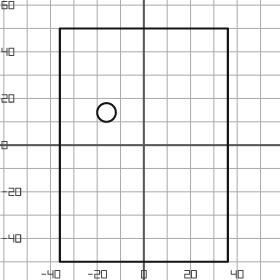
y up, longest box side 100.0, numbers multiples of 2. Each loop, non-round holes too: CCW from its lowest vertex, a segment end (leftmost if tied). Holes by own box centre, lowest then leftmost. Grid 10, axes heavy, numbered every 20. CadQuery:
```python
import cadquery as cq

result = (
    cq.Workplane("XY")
    .moveTo(-36.0, -50.0)
    .lineTo(36.0, -50.0)
    .lineTo(36.0, 50.0)
    .lineTo(-36.0, 50.0)
    .close()
    .moveTo(-16.0, 14.0)
    .circle(4.0)
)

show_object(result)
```